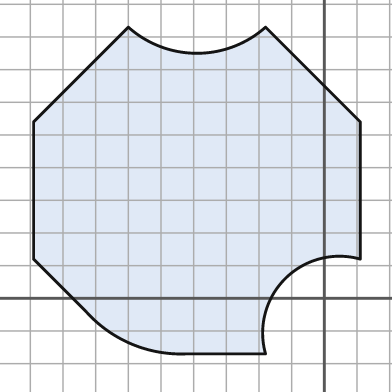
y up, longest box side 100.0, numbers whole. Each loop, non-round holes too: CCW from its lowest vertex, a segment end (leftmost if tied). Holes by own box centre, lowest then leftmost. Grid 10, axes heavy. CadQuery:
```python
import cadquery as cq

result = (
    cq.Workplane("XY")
    .moveTo(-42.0, -17.0)
    .lineTo(-18.0, -17.0)
    .threePointArc((-12.0, 6.0), (11.0, 12.0))
    .lineTo(11.0, 54.0)
    .lineTo(-18.0, 83.0)
    .threePointArc((-39.0, 75.0), (-60.0, 83.0))
    .lineTo(-89.0, 54.0)
    .lineTo(-89.0, 12.0)
    .lineTo(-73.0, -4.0)
    .threePointArc((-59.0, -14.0), (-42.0, -17.0))
    .close()
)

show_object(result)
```